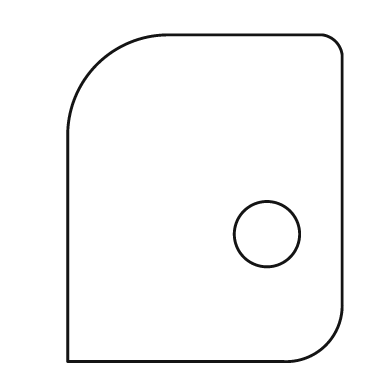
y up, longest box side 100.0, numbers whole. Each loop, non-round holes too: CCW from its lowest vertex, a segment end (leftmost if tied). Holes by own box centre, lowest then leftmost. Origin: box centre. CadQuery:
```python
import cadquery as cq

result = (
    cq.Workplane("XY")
    .moveTo(-42.0, -50.0)
    .lineTo(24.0, -50.0)
    .threePointArc((37.0, -45.0), (42.0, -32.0))
    .lineTo(42.0, 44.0)
    .threePointArc((40.0, 48.0), (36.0, 50.0))
    .lineTo(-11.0, 50.0)
    .threePointArc((-33.0, 41.0), (-42.0, 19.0))
    .close()
    .moveTo(19.0, -11.0)
    .circle(10.0)
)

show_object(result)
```